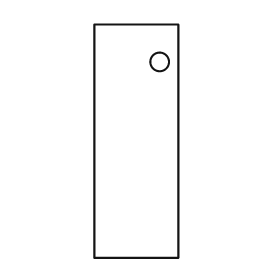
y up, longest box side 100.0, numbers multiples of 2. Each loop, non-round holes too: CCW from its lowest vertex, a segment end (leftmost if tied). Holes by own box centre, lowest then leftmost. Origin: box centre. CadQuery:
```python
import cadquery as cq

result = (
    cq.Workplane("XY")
    .moveTo(-18.0, -50.0)
    .lineTo(18.0, -50.0)
    .lineTo(18.0, 50.0)
    .lineTo(-18.0, 50.0)
    .close()
    .moveTo(10.0, 34.0)
    .circle(4.0)
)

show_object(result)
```